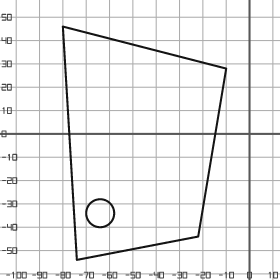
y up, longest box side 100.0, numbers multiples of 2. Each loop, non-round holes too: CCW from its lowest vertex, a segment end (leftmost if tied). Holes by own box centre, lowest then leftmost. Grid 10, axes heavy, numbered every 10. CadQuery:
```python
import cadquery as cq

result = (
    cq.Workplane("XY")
    .moveTo(-74.0, -54.0)
    .lineTo(-22.0, -44.0)
    .lineTo(-10.0, 28.0)
    .lineTo(-80.0, 46.0)
    .close()
    .moveTo(-64.0, -34.0)
    .circle(6.0)
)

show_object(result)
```